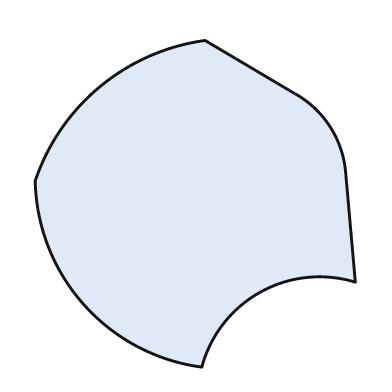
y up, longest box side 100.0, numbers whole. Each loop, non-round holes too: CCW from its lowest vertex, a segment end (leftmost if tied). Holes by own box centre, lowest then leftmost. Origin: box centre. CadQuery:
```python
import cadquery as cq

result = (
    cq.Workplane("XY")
    .moveTo(2.0, -50.0)
    .threePointArc((20.0, -27.0), (49.0, -24.0))
    .lineTo(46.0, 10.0)
    .threePointArc((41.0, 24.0), (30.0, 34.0))
    .lineTo(3.0, 50.0)
    .threePointArc((-29.0, 36.0), (-49.0, 7.0))
    .threePointArc((-34.0, -31.0), (2.0, -50.0))
    .close()
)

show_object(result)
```